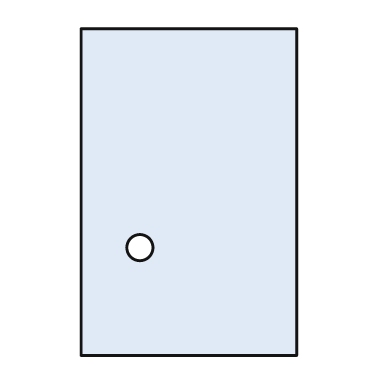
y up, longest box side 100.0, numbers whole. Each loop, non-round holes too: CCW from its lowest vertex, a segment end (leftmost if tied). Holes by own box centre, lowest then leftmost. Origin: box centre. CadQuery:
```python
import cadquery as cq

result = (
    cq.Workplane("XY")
    .moveTo(-33.0, -50.0)
    .lineTo(33.0, -50.0)
    .lineTo(33.0, 50.0)
    .lineTo(-33.0, 50.0)
    .close()
    .moveTo(-15.0, -17.0)
    .circle(4.0)
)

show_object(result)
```